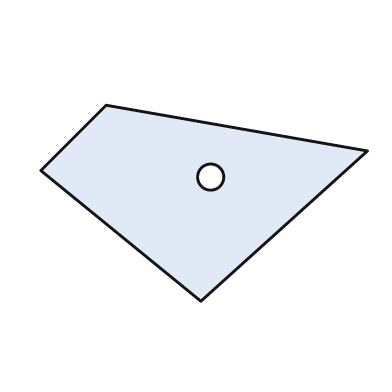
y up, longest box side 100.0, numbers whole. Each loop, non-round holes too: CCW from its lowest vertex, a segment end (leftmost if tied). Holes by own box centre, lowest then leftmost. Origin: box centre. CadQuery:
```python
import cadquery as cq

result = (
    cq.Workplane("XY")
    .moveTo(-1.0, -30.0)
    .lineTo(50.0, 16.0)
    .lineTo(-30.0, 30.0)
    .lineTo(-50.0, 10.0)
    .close()
    .moveTo(2.0, 8.0)
    .circle(4.0)
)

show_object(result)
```